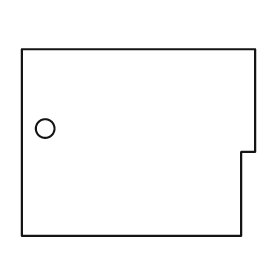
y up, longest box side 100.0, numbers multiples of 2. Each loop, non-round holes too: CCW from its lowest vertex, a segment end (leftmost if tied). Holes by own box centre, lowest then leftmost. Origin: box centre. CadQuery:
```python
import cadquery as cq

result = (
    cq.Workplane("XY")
    .moveTo(-50.0, -40.0)
    .lineTo(44.0, -40.0)
    .lineTo(44.0, -4.0)
    .lineTo(50.0, -4.0)
    .lineTo(50.0, 40.0)
    .lineTo(-50.0, 40.0)
    .close()
    .moveTo(-40.0, 6.0)
    .circle(4.0)
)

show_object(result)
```